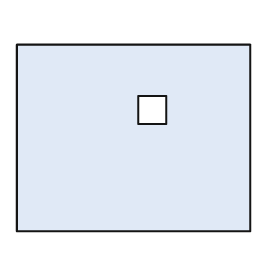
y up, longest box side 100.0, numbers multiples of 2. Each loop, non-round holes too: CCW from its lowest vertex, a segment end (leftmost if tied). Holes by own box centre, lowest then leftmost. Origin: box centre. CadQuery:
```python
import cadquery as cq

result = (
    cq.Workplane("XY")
    .moveTo(-50.0, -40.0)
    .lineTo(50.0, -40.0)
    .lineTo(50.0, 40.0)
    .lineTo(-50.0, 40.0)
    .close()
    .moveTo(2.0, 6.0)
    .lineTo(14.0, 6.0)
    .lineTo(14.0, 18.0)
    .lineTo(2.0, 18.0)
    .close()
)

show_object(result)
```